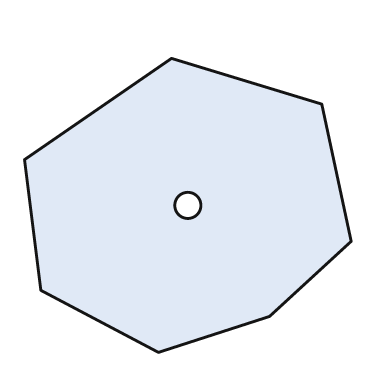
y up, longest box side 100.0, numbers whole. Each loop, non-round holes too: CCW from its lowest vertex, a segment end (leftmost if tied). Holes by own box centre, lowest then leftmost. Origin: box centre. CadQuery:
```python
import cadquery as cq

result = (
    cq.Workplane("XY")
    .moveTo(-9.0, -45.0)
    .lineTo(25.0, -34.0)
    .lineTo(50.0, -11.0)
    .lineTo(41.0, 31.0)
    .lineTo(-5.0, 45.0)
    .lineTo(-50.0, 14.0)
    .lineTo(-45.0, -26.0)
    .close()
    .moveTo(0.0, 0.0)
    .circle(4.0)
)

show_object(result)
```